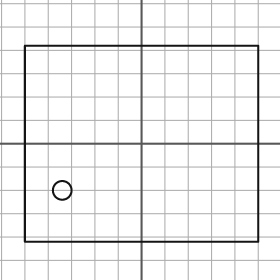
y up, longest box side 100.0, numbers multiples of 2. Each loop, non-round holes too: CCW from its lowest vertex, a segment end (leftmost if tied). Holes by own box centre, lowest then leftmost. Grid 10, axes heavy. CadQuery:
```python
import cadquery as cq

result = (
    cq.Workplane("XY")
    .moveTo(-50.0, -42.0)
    .lineTo(50.0, -42.0)
    .lineTo(50.0, 42.0)
    .lineTo(-50.0, 42.0)
    .close()
    .moveTo(-34.0, -20.0)
    .circle(4.0)
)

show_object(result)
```